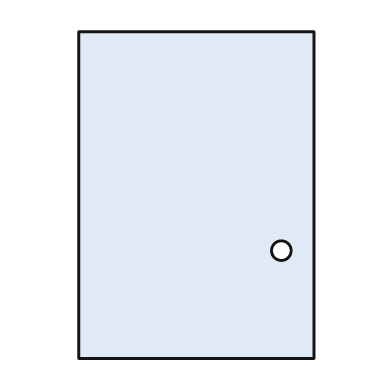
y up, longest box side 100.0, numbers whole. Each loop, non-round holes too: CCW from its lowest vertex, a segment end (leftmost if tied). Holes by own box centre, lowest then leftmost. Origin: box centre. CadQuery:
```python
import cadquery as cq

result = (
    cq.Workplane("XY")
    .moveTo(-36.0, -50.0)
    .lineTo(36.0, -50.0)
    .lineTo(36.0, 50.0)
    .lineTo(-36.0, 50.0)
    .close()
    .moveTo(26.0, -17.0)
    .circle(3.0)
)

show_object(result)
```